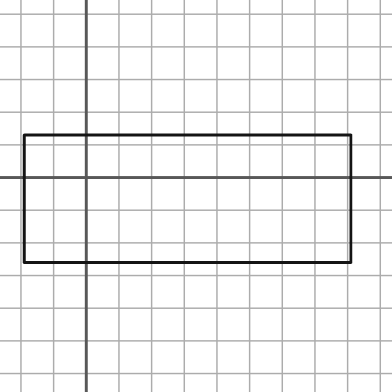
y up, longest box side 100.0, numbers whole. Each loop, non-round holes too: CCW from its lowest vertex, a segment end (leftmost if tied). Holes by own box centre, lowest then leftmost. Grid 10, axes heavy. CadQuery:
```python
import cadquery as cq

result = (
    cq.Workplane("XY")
    .moveTo(-19.0, -26.0)
    .lineTo(81.0, -26.0)
    .lineTo(81.0, 13.0)
    .lineTo(-19.0, 13.0)
    .close()
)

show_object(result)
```